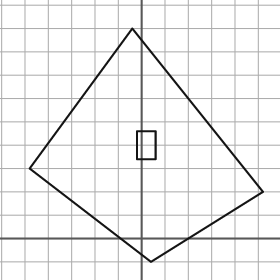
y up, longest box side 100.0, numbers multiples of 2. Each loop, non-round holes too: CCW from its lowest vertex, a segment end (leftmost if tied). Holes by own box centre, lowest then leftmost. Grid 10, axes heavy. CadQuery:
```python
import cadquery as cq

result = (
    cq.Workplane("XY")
    .moveTo(4.0, -10.0)
    .lineTo(52.0, 20.0)
    .lineTo(-4.0, 90.0)
    .lineTo(-48.0, 30.0)
    .close()
    .moveTo(-2.0, 34.0)
    .lineTo(6.0, 34.0)
    .lineTo(6.0, 46.0)
    .lineTo(-2.0, 46.0)
    .close()
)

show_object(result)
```